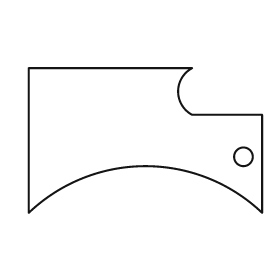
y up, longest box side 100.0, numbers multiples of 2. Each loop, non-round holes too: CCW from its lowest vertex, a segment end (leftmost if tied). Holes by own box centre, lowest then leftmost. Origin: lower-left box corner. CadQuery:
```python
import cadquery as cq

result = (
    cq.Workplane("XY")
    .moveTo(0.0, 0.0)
    .threePointArc((50.0, 20.0), (100.0, 0.0))
    .lineTo(100.0, 42.0)
    .lineTo(70.0, 42.0)
    .threePointArc((64.0, 52.0), (70.0, 62.0))
    .lineTo(0.0, 62.0)
    .close()
    .moveTo(92.0, 24.0)
    .circle(4.0)
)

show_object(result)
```